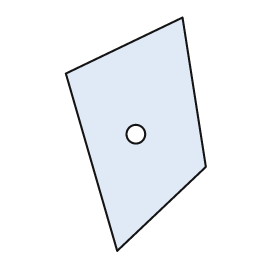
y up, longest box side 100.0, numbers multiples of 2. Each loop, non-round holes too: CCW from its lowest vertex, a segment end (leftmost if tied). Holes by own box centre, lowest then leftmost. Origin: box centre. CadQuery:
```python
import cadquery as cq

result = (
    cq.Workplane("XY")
    .moveTo(-8.0, -50.0)
    .lineTo(30.0, -14.0)
    .lineTo(20.0, 50.0)
    .lineTo(-30.0, 26.0)
    .close()
    .moveTo(0.0, 0.0)
    .circle(4.0)
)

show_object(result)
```